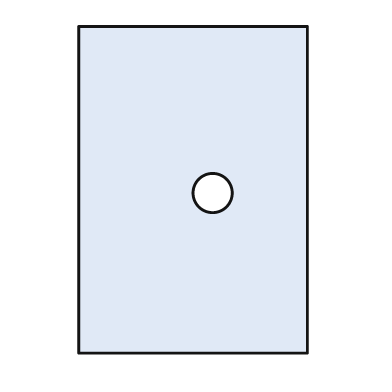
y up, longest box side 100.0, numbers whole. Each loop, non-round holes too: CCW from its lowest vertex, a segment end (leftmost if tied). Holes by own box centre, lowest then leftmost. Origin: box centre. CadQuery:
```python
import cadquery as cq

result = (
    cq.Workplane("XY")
    .moveTo(-35.0, -50.0)
    .lineTo(35.0, -50.0)
    .lineTo(35.0, 50.0)
    .lineTo(-35.0, 50.0)
    .close()
    .moveTo(6.0, -1.0)
    .circle(6.0)
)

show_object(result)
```